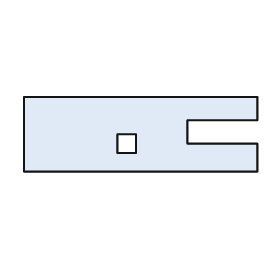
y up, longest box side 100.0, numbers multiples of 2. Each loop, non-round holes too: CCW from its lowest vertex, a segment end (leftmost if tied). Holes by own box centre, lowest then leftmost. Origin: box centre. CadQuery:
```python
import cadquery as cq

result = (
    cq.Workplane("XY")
    .moveTo(-50.0, -16.0)
    .lineTo(50.0, -16.0)
    .lineTo(50.0, -4.0)
    .lineTo(20.0, -4.0)
    .lineTo(20.0, 6.0)
    .lineTo(50.0, 6.0)
    .lineTo(50.0, 16.0)
    .lineTo(-50.0, 16.0)
    .close()
    .moveTo(-10.0, -8.0)
    .lineTo(-2.0, -8.0)
    .lineTo(-2.0, 0.0)
    .lineTo(-10.0, 0.0)
    .close()
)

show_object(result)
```